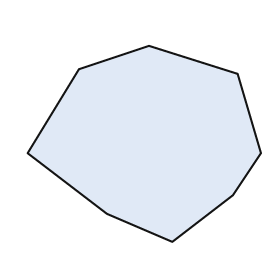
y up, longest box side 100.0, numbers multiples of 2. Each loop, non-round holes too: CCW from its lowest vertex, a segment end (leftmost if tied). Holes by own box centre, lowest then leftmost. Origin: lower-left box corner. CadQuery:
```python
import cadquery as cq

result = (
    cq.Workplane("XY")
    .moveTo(62.0, 0.0)
    .lineTo(88.0, 20.0)
    .lineTo(100.0, 38.0)
    .lineTo(90.0, 72.0)
    .lineTo(52.0, 84.0)
    .lineTo(22.0, 74.0)
    .lineTo(0.0, 38.0)
    .lineTo(34.0, 12.0)
    .close()
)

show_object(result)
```